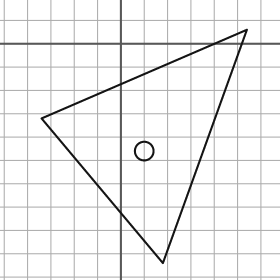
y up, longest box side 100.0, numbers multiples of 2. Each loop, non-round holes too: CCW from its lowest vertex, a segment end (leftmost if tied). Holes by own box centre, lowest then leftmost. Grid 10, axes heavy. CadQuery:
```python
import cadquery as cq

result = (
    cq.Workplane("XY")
    .moveTo(18.0, -94.0)
    .lineTo(54.0, 6.0)
    .lineTo(-34.0, -32.0)
    .close()
    .moveTo(10.0, -46.0)
    .circle(4.0)
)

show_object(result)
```